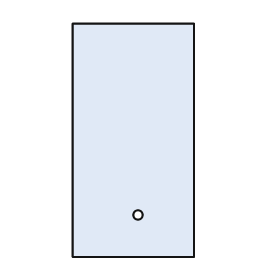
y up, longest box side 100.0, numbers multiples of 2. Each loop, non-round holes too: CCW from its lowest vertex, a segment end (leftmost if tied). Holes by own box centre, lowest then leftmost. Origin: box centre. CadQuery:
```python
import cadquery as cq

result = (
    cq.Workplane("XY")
    .moveTo(-26.0, -50.0)
    .lineTo(26.0, -50.0)
    .lineTo(26.0, 50.0)
    .lineTo(-26.0, 50.0)
    .close()
    .moveTo(2.0, -32.0)
    .circle(2.0)
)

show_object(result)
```